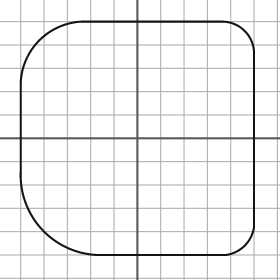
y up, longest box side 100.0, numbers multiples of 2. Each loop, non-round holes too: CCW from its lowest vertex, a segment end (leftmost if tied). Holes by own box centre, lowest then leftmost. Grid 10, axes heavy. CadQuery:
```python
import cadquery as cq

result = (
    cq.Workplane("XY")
    .moveTo(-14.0, -50.0)
    .lineTo(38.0, -50.0)
    .threePointArc((46.0, -46.0), (50.0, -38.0))
    .lineTo(50.0, 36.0)
    .threePointArc((46.0, 46.0), (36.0, 50.0))
    .lineTo(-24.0, 50.0)
    .threePointArc((-42.0, 42.0), (-50.0, 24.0))
    .lineTo(-50.0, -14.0)
    .threePointArc((-40.0, -40.0), (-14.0, -50.0))
    .close()
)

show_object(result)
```